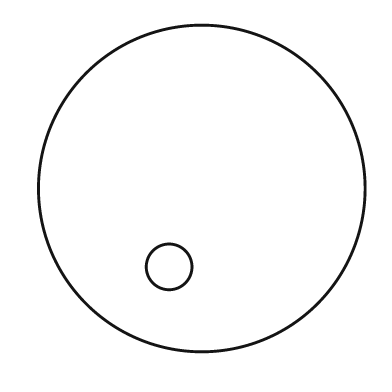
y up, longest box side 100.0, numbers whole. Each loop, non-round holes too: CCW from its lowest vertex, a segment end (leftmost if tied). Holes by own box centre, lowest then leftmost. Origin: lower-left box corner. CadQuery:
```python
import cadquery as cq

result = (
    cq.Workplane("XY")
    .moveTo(50.0, 50.0)
    .circle(50.0)
    .moveTo(40.0, 26.0)
    .circle(7.0)
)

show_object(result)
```